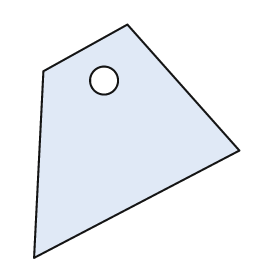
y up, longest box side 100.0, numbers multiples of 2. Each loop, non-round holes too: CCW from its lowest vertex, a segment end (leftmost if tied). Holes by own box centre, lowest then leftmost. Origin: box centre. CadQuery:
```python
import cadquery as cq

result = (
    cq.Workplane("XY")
    .moveTo(-44.0, -50.0)
    .lineTo(44.0, -4.0)
    .lineTo(-4.0, 50.0)
    .lineTo(-40.0, 30.0)
    .close()
    .moveTo(-14.0, 26.0)
    .circle(6.0)
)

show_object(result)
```